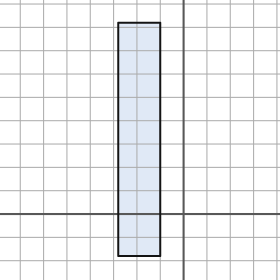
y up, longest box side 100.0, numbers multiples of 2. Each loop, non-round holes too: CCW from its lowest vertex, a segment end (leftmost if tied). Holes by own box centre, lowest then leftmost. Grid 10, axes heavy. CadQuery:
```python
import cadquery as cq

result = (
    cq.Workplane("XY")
    .moveTo(-28.0, -18.0)
    .lineTo(-10.0, -18.0)
    .lineTo(-10.0, 82.0)
    .lineTo(-28.0, 82.0)
    .close()
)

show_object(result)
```